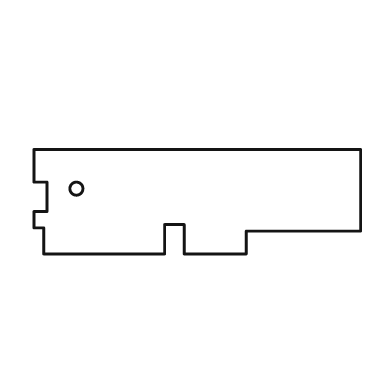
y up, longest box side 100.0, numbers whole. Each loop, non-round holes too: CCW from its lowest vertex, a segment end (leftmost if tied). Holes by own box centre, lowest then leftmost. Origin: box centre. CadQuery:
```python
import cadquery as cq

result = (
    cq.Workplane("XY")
    .moveTo(-47.0, -16.0)
    .lineTo(-10.0, -16.0)
    .lineTo(-10.0, -7.0)
    .lineTo(-4.0, -7.0)
    .lineTo(-4.0, -16.0)
    .lineTo(15.0, -16.0)
    .lineTo(15.0, -9.0)
    .lineTo(50.0, -9.0)
    .lineTo(50.0, 16.0)
    .lineTo(-50.0, 16.0)
    .lineTo(-50.0, 6.0)
    .lineTo(-46.0, 6.0)
    .lineTo(-46.0, -3.0)
    .lineTo(-50.0, -3.0)
    .lineTo(-50.0, -8.0)
    .lineTo(-47.0, -8.0)
    .close()
    .moveTo(-37.0, 4.0)
    .circle(2.0)
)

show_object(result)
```